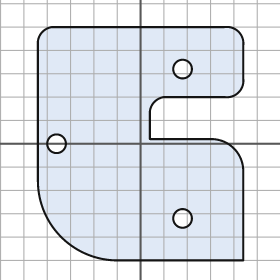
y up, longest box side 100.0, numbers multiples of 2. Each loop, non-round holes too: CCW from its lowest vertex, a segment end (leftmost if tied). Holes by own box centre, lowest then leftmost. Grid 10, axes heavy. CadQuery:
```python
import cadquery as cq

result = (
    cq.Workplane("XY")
    .moveTo(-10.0, -50.0)
    .lineTo(44.0, -50.0)
    .lineTo(44.0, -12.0)
    .threePointArc((40.0, -2.0), (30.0, 2.0))
    .lineTo(4.0, 2.0)
    .lineTo(4.0, 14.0)
    .threePointArc((6.0, 18.0), (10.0, 20.0))
    .lineTo(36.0, 20.0)
    .threePointArc((42.0, 22.0), (44.0, 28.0))
    .lineTo(44.0, 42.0)
    .threePointArc((42.0, 48.0), (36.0, 50.0))
    .lineTo(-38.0, 50.0)
    .threePointArc((-42.0, 48.0), (-44.0, 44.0))
    .lineTo(-44.0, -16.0)
    .threePointArc((-34.0, -40.0), (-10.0, -50.0))
    .close()
    .moveTo(18.0, -32.0)
    .circle(4.0)
    .moveTo(-36.0, 0.0)
    .circle(4.0)
    .moveTo(18.0, 32.0)
    .circle(4.0)
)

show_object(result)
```